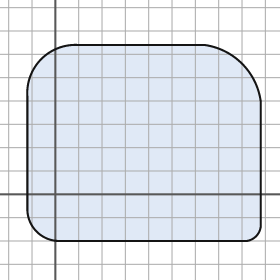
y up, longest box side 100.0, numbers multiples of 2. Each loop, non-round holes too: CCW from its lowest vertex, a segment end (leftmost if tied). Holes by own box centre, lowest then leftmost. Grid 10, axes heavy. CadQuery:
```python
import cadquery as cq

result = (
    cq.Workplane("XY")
    .moveTo(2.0, -20.0)
    .lineTo(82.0, -20.0)
    .threePointArc((86.0, -18.0), (88.0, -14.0))
    .lineTo(88.0, 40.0)
    .threePointArc((80.0, 56.0), (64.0, 64.0))
    .lineTo(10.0, 64.0)
    .threePointArc((-6.0, 58.0), (-12.0, 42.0))
    .lineTo(-12.0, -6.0)
    .threePointArc((-8.0, -16.0), (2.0, -20.0))
    .close()
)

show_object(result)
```